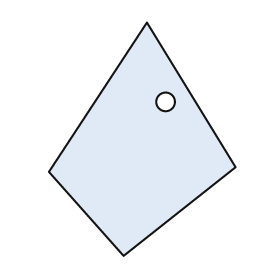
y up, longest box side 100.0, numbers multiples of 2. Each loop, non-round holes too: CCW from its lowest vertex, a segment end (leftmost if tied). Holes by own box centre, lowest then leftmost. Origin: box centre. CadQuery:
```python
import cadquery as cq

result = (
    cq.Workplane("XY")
    .moveTo(-8.0, -50.0)
    .lineTo(40.0, -12.0)
    .lineTo(2.0, 50.0)
    .lineTo(-40.0, -14.0)
    .close()
    .moveTo(10.0, 16.0)
    .circle(4.0)
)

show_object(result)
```